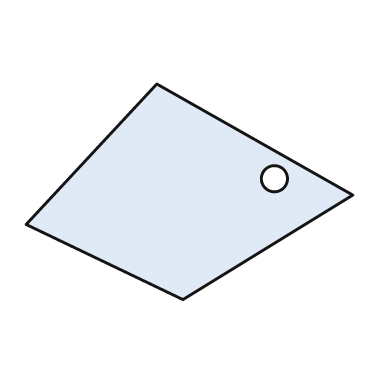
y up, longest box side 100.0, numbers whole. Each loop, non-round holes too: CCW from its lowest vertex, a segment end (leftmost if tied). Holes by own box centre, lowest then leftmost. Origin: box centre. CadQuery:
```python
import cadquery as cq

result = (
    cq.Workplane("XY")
    .moveTo(-2.0, -33.0)
    .lineTo(50.0, -1.0)
    .lineTo(-10.0, 33.0)
    .lineTo(-50.0, -10.0)
    .close()
    .moveTo(26.0, 4.0)
    .circle(4.0)
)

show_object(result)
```